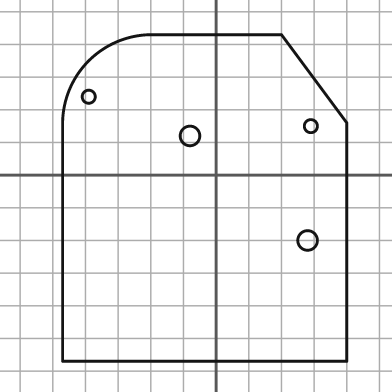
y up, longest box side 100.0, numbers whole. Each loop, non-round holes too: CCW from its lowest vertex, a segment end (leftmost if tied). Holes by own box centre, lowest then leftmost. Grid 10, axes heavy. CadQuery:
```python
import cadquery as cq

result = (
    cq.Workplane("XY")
    .moveTo(-47.0, -57.0)
    .lineTo(40.0, -57.0)
    .lineTo(40.0, 16.0)
    .lineTo(20.0, 43.0)
    .lineTo(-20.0, 43.0)
    .threePointArc((-39.0, 35.0), (-47.0, 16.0))
    .close()
    .moveTo(28.0, -20.0)
    .circle(3.0)
    .moveTo(-8.0, 12.0)
    .circle(3.0)
    .moveTo(29.0, 15.0)
    .circle(2.0)
    .moveTo(-39.0, 24.0)
    .circle(2.0)
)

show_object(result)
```